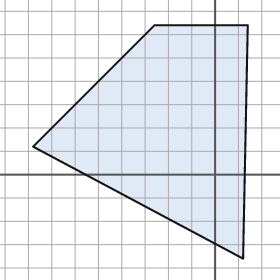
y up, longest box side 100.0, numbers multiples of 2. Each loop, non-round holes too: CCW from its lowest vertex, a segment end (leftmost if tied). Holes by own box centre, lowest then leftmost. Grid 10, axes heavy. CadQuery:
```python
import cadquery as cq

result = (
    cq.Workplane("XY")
    .moveTo(12.0, -36.0)
    .lineTo(14.0, 64.0)
    .lineTo(-26.0, 64.0)
    .lineTo(-78.0, 12.0)
    .close()
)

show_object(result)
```